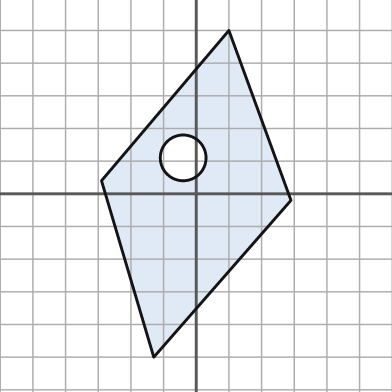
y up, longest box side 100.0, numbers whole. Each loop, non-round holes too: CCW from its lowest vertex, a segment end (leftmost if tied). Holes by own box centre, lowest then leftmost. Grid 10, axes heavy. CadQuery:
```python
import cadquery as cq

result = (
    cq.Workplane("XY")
    .moveTo(-13.0, -50.0)
    .lineTo(29.0, -2.0)
    .lineTo(10.0, 50.0)
    .lineTo(-29.0, 4.0)
    .close()
    .moveTo(-4.0, 11.0)
    .circle(7.0)
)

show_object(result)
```